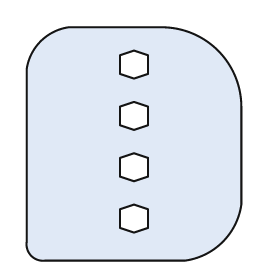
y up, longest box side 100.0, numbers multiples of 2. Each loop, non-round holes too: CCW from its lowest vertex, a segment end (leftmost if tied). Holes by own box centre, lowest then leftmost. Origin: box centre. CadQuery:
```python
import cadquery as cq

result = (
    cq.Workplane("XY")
    .moveTo(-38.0, -50.0)
    .lineTo(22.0, -50.0)
    .threePointArc((38.0, -42.0), (46.0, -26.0))
    .lineTo(46.0, 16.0)
    .threePointArc((36.0, 40.0), (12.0, 50.0))
    .lineTo(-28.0, 50.0)
    .threePointArc((-40.0, 44.0), (-46.0, 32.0))
    .lineTo(-46.0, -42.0)
    .threePointArc((-44.0, -48.0), (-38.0, -50.0))
    .close()
    .moveTo(0.0, -38.0)
    .lineTo(6.0, -36.0)
    .lineTo(6.0, -28.0)
    .lineTo(0.0, -26.0)
    .lineTo(-6.0, -28.0)
    .lineTo(-6.0, -36.0)
    .close()
    .moveTo(0.0, -16.0)
    .lineTo(6.0, -14.0)
    .lineTo(6.0, -6.0)
    .lineTo(0.0, -4.0)
    .lineTo(-6.0, -6.0)
    .lineTo(-6.0, -14.0)
    .close()
    .moveTo(0.0, 6.0)
    .lineTo(6.0, 8.0)
    .lineTo(6.0, 16.0)
    .lineTo(0.0, 18.0)
    .lineTo(-6.0, 16.0)
    .lineTo(-6.0, 8.0)
    .close()
    .moveTo(0.0, 28.0)
    .lineTo(6.0, 30.0)
    .lineTo(6.0, 38.0)
    .lineTo(0.0, 40.0)
    .lineTo(-6.0, 38.0)
    .lineTo(-6.0, 30.0)
    .close()
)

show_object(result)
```